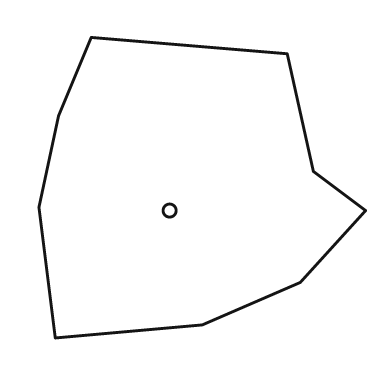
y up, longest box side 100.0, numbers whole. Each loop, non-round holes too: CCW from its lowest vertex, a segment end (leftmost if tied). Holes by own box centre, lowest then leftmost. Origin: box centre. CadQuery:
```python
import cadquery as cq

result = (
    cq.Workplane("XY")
    .moveTo(-45.0, -46.0)
    .lineTo(0.0, -42.0)
    .lineTo(30.0, -29.0)
    .lineTo(50.0, -7.0)
    .lineTo(34.0, 5.0)
    .lineTo(26.0, 41.0)
    .lineTo(-34.0, 46.0)
    .lineTo(-44.0, 22.0)
    .lineTo(-50.0, -6.0)
    .close()
    .moveTo(-10.0, -7.0)
    .circle(2.0)
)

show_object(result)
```